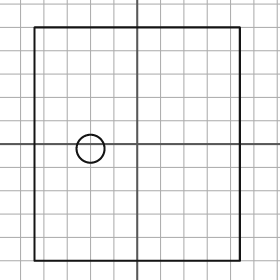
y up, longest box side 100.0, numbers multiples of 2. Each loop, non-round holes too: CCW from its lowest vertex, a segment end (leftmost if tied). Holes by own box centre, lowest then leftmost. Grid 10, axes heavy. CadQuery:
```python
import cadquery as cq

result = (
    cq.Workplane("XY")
    .moveTo(-44.0, -50.0)
    .lineTo(44.0, -50.0)
    .lineTo(44.0, 50.0)
    .lineTo(-44.0, 50.0)
    .close()
    .moveTo(-20.0, -2.0)
    .circle(6.0)
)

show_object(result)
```